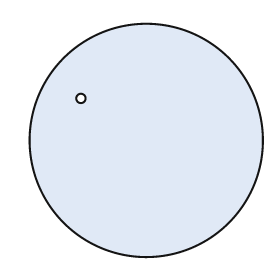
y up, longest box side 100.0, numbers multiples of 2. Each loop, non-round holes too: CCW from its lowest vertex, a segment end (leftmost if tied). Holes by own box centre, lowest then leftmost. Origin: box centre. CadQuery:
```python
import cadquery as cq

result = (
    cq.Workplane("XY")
    .moveTo(0.0, 0.0)
    .circle(50.0)
    .moveTo(-28.0, 18.0)
    .circle(2.0)
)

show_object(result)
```